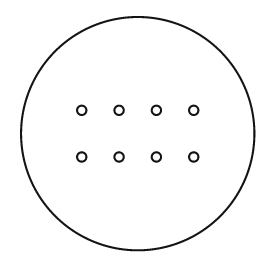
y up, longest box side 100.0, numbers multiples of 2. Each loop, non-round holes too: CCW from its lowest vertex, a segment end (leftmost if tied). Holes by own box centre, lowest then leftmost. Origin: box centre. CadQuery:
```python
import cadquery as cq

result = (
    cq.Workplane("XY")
    .moveTo(0.0, 0.0)
    .circle(50.0)
    .moveTo(-24.0, -10.0)
    .circle(2.0)
    .moveTo(-8.0, -10.0)
    .circle(2.0)
    .moveTo(8.0, -10.0)
    .circle(2.0)
    .moveTo(24.0, -10.0)
    .circle(2.0)
    .moveTo(-24.0, 10.0)
    .circle(2.0)
    .moveTo(-8.0, 10.0)
    .circle(2.0)
    .moveTo(8.0, 10.0)
    .circle(2.0)
    .moveTo(24.0, 10.0)
    .circle(2.0)
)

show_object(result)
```